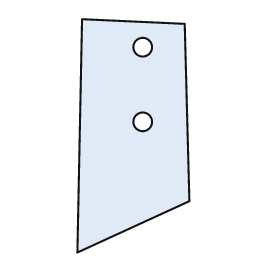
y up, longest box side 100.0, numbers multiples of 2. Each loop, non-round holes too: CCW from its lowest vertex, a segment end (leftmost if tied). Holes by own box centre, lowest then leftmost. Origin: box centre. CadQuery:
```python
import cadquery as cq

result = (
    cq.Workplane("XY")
    .moveTo(-24.0, -50.0)
    .lineTo(24.0, -28.0)
    .lineTo(22.0, 48.0)
    .lineTo(-22.0, 50.0)
    .close()
    .moveTo(4.0, 6.0)
    .circle(4.0)
    .moveTo(4.0, 38.0)
    .circle(4.0)
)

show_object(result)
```